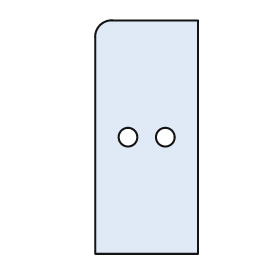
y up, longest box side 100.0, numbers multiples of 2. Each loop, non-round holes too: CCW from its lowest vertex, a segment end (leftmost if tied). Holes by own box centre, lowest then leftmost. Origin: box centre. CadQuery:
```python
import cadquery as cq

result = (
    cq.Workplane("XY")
    .moveTo(-22.0, -50.0)
    .lineTo(22.0, -50.0)
    .lineTo(22.0, 50.0)
    .lineTo(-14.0, 50.0)
    .threePointArc((-20.0, 48.0), (-22.0, 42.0))
    .close()
    .moveTo(-8.0, 0.0)
    .circle(4.0)
    .moveTo(8.0, 0.0)
    .circle(4.0)
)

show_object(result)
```